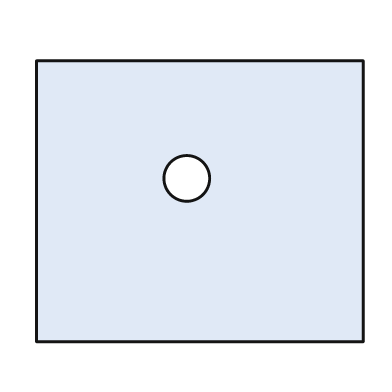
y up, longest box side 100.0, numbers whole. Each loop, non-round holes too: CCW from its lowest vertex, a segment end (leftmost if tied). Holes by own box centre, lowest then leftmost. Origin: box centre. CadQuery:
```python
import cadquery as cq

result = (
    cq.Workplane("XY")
    .moveTo(-50.0, -43.0)
    .lineTo(50.0, -43.0)
    .lineTo(50.0, 43.0)
    .lineTo(-50.0, 43.0)
    .close()
    .moveTo(-4.0, 7.0)
    .circle(7.0)
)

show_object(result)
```